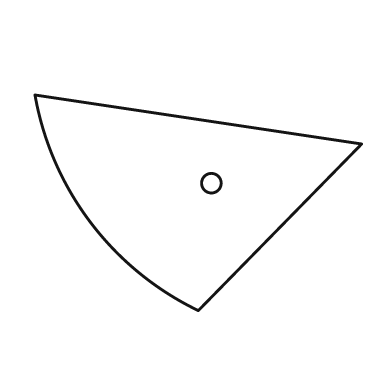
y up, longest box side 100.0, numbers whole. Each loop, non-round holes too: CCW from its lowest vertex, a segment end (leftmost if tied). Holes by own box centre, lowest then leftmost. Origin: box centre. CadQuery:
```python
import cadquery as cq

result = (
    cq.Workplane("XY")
    .moveTo(0.0, -33.0)
    .lineTo(50.0, 18.0)
    .lineTo(-50.0, 33.0)
    .threePointArc((-33.0, -6.0), (0.0, -33.0))
    .close()
    .moveTo(4.0, 6.0)
    .circle(3.0)
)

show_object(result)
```